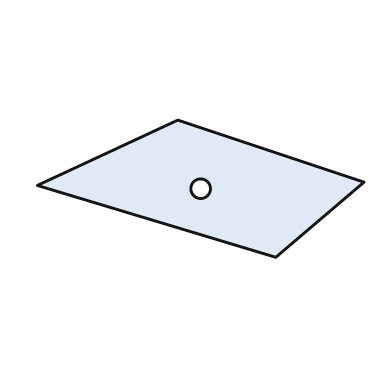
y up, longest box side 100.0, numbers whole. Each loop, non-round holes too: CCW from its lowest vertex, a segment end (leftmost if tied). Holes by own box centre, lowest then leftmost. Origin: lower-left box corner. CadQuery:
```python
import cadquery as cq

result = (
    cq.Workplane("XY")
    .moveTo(73.0, 0.0)
    .lineTo(100.0, 23.0)
    .lineTo(43.0, 42.0)
    .lineTo(0.0, 22.0)
    .close()
    .moveTo(50.0, 21.0)
    .circle(3.0)
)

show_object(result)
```